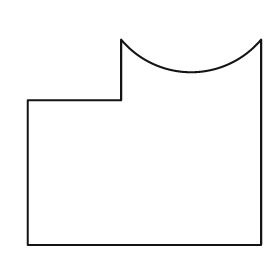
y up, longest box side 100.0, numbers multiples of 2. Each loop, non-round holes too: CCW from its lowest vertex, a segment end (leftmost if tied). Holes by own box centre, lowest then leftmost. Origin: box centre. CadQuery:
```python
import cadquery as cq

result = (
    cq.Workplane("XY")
    .moveTo(-50.0, -44.0)
    .lineTo(50.0, -44.0)
    .lineTo(50.0, 44.0)
    .threePointArc((20.0, 30.0), (-10.0, 44.0))
    .lineTo(-10.0, 18.0)
    .lineTo(-50.0, 18.0)
    .close()
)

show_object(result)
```